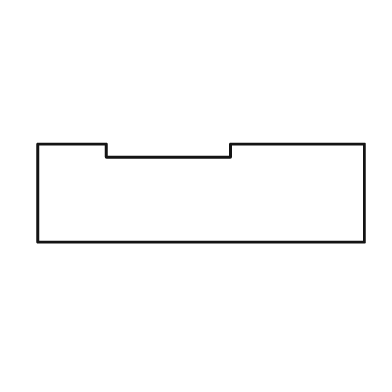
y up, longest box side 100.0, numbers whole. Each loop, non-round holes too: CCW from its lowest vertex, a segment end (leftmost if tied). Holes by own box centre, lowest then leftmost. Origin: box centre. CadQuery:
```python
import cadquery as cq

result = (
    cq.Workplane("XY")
    .moveTo(-50.0, -15.0)
    .lineTo(50.0, -15.0)
    .lineTo(50.0, 15.0)
    .lineTo(9.0, 15.0)
    .lineTo(9.0, 11.0)
    .lineTo(-29.0, 11.0)
    .lineTo(-29.0, 15.0)
    .lineTo(-50.0, 15.0)
    .close()
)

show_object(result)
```